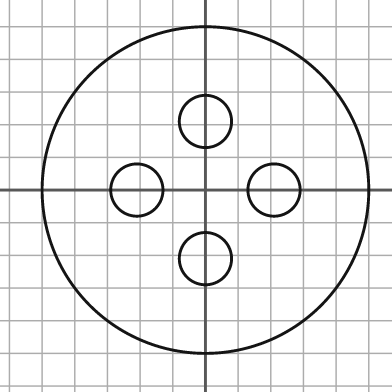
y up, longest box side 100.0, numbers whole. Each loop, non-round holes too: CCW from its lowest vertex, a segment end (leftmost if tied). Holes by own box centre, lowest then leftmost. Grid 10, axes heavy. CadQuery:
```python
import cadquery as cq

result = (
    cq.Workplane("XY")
    .moveTo(0.0, 0.0)
    .circle(50.0)
    .moveTo(0.0, -21.0)
    .circle(8.0)
    .moveTo(-21.0, 0.0)
    .circle(8.0)
    .moveTo(21.0, 0.0)
    .circle(8.0)
    .moveTo(0.0, 21.0)
    .circle(8.0)
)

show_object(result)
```